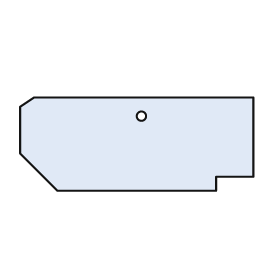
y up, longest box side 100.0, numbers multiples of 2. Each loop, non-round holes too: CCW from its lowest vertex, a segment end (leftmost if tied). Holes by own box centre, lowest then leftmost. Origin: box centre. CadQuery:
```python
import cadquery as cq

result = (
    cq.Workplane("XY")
    .moveTo(-34.0, -20.0)
    .lineTo(34.0, -20.0)
    .lineTo(34.0, -14.0)
    .lineTo(50.0, -14.0)
    .lineTo(50.0, 20.0)
    .lineTo(-44.0, 20.0)
    .lineTo(-50.0, 16.0)
    .lineTo(-50.0, -4.0)
    .close()
    .moveTo(2.0, 12.0)
    .circle(2.0)
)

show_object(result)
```